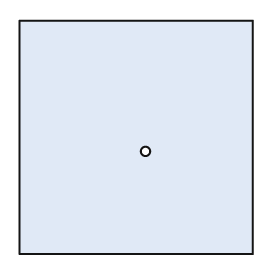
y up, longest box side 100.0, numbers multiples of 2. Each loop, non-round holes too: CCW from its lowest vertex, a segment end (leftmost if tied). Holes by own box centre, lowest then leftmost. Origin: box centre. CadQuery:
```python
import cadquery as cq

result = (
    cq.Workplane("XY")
    .moveTo(-50.0, -50.0)
    .lineTo(50.0, -50.0)
    .lineTo(50.0, 50.0)
    .lineTo(-50.0, 50.0)
    .close()
    .moveTo(4.0, -6.0)
    .circle(2.0)
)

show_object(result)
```